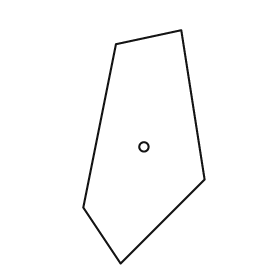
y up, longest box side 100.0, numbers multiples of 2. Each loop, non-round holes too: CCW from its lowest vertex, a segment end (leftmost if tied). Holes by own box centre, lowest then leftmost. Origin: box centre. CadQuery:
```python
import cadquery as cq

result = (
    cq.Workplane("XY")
    .moveTo(-10.0, -50.0)
    .lineTo(26.0, -14.0)
    .lineTo(16.0, 50.0)
    .lineTo(-12.0, 44.0)
    .lineTo(-26.0, -26.0)
    .close()
    .moveTo(0.0, 0.0)
    .circle(2.0)
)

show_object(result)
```